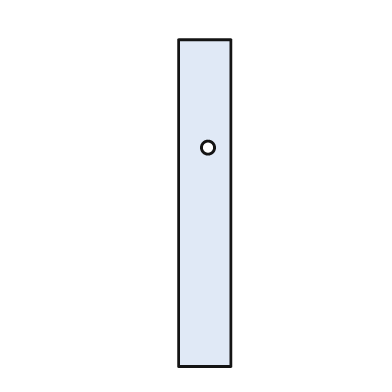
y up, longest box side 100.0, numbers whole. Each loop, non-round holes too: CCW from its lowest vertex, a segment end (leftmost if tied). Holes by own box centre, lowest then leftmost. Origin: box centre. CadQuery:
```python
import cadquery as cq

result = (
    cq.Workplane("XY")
    .moveTo(-8.0, -50.0)
    .lineTo(8.0, -50.0)
    .lineTo(8.0, 50.0)
    .lineTo(-8.0, 50.0)
    .close()
    .moveTo(1.0, 17.0)
    .circle(2.0)
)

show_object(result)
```